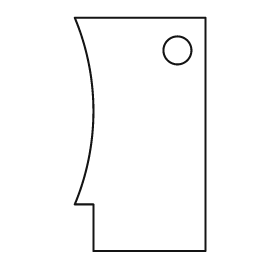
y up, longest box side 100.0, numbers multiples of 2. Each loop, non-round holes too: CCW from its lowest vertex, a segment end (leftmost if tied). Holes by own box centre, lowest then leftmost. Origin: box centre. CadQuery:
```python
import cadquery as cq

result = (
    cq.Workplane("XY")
    .moveTo(-20.0, -50.0)
    .lineTo(28.0, -50.0)
    .lineTo(28.0, 50.0)
    .lineTo(-28.0, 50.0)
    .threePointArc((-20.0, 10.0), (-28.0, -30.0))
    .lineTo(-20.0, -30.0)
    .close()
    .moveTo(16.0, 36.0)
    .circle(6.0)
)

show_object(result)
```